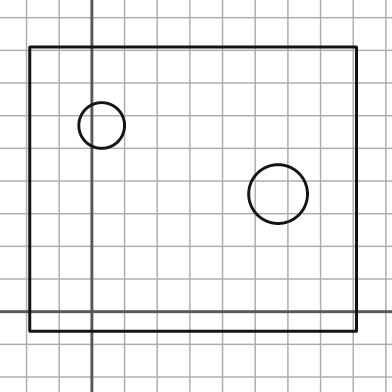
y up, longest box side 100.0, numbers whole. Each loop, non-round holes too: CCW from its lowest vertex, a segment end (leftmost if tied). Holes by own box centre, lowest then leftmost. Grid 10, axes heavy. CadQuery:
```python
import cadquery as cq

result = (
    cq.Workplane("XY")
    .moveTo(-19.0, -6.0)
    .lineTo(81.0, -6.0)
    .lineTo(81.0, 81.0)
    .lineTo(-19.0, 81.0)
    .close()
    .moveTo(57.0, 36.0)
    .circle(9.0)
    .moveTo(3.0, 57.0)
    .circle(7.0)
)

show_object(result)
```